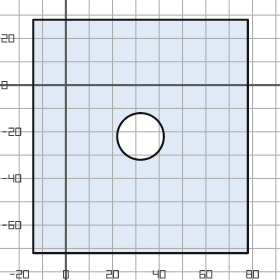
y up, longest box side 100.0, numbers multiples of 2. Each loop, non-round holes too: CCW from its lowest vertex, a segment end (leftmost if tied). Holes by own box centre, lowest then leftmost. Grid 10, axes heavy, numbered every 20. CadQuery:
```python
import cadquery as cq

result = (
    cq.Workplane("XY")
    .moveTo(-14.0, -72.0)
    .lineTo(78.0, -72.0)
    .lineTo(78.0, 28.0)
    .lineTo(-14.0, 28.0)
    .close()
    .moveTo(32.0, -22.0)
    .circle(10.0)
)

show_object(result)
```